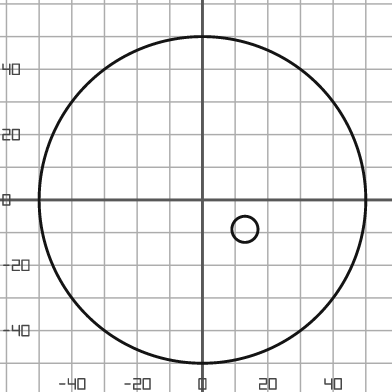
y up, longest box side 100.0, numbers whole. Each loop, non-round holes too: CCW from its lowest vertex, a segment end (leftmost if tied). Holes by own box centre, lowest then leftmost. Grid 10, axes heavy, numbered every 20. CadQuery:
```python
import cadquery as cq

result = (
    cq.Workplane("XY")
    .moveTo(0.0, 0.0)
    .circle(50.0)
    .moveTo(13.0, -9.0)
    .circle(4.0)
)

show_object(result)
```